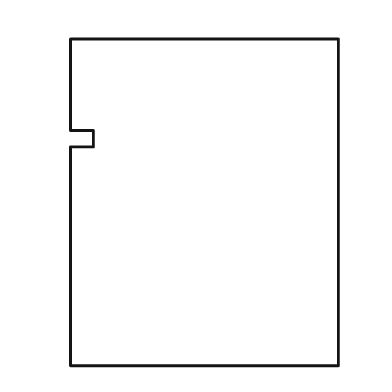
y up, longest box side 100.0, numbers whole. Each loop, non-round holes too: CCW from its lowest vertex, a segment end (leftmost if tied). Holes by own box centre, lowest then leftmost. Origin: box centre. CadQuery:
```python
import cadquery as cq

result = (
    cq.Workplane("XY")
    .moveTo(-41.0, -50.0)
    .lineTo(41.0, -50.0)
    .lineTo(41.0, 50.0)
    .lineTo(-41.0, 50.0)
    .lineTo(-41.0, 22.0)
    .lineTo(-34.0, 22.0)
    .lineTo(-34.0, 17.0)
    .lineTo(-41.0, 17.0)
    .close()
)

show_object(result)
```